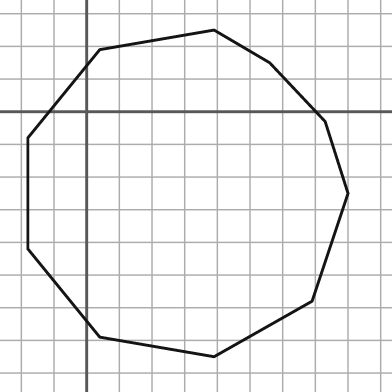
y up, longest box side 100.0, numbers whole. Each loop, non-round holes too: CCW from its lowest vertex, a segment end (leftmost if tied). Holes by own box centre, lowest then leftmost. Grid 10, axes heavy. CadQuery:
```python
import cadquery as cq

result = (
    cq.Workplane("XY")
    .moveTo(39.0, -75.0)
    .lineTo(69.0, -58.0)
    .lineTo(80.0, -25.0)
    .lineTo(73.0, -3.0)
    .lineTo(56.0, 15.0)
    .lineTo(39.0, 25.0)
    .lineTo(4.0, 19.0)
    .lineTo(-18.0, -8.0)
    .lineTo(-18.0, -42.0)
    .lineTo(4.0, -69.0)
    .close()
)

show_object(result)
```